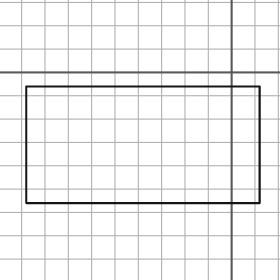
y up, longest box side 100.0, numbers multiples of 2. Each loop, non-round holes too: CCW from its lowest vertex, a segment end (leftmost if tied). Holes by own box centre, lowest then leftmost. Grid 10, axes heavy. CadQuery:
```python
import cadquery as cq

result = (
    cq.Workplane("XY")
    .moveTo(-88.0, -56.0)
    .lineTo(12.0, -56.0)
    .lineTo(12.0, -6.0)
    .lineTo(-88.0, -6.0)
    .close()
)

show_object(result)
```